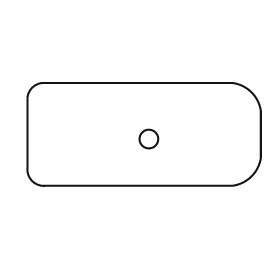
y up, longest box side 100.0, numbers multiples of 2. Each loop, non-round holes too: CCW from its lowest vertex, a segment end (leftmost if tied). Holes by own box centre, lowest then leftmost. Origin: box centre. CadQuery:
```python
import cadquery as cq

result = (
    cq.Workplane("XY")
    .moveTo(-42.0, -22.0)
    .lineTo(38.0, -22.0)
    .threePointArc((46.0, -18.0), (50.0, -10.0))
    .lineTo(50.0, 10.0)
    .threePointArc((46.0, 18.0), (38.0, 22.0))
    .lineTo(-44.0, 22.0)
    .threePointArc((-48.0, 20.0), (-50.0, 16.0))
    .lineTo(-50.0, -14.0)
    .threePointArc((-48.0, -20.0), (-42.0, -22.0))
    .close()
    .moveTo(2.0, -2.0)
    .circle(4.0)
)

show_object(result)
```